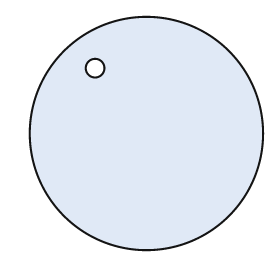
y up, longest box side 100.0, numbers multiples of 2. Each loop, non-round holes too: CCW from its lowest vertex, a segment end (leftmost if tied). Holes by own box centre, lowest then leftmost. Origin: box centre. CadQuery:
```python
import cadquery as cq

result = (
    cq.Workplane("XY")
    .moveTo(0.0, 0.0)
    .circle(50.0)
    .moveTo(-22.0, 28.0)
    .circle(4.0)
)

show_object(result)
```